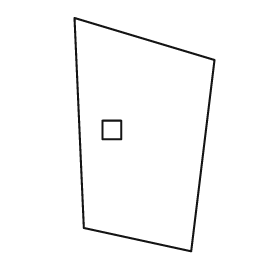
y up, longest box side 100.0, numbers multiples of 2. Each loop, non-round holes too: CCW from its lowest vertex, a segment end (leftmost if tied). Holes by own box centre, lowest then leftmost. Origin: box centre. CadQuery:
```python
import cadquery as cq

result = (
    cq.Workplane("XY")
    .moveTo(20.0, -50.0)
    .lineTo(30.0, 32.0)
    .lineTo(-30.0, 50.0)
    .lineTo(-26.0, -40.0)
    .close()
    .moveTo(-18.0, -2.0)
    .lineTo(-10.0, -2.0)
    .lineTo(-10.0, 6.0)
    .lineTo(-18.0, 6.0)
    .close()
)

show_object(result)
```